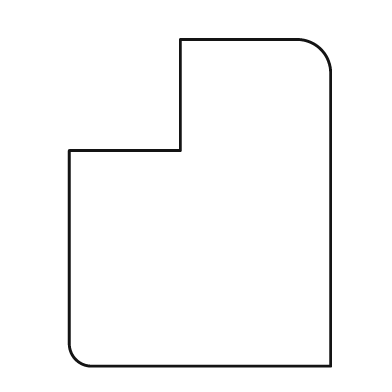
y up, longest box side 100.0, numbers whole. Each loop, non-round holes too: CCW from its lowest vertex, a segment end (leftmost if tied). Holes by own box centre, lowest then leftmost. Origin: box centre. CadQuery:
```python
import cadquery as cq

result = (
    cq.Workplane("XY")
    .moveTo(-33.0, -50.0)
    .lineTo(40.0, -50.0)
    .lineTo(40.0, 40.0)
    .threePointArc((37.0, 47.0), (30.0, 50.0))
    .lineTo(-6.0, 50.0)
    .lineTo(-6.0, 16.0)
    .lineTo(-40.0, 16.0)
    .lineTo(-40.0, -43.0)
    .threePointArc((-38.0, -48.0), (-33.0, -50.0))
    .close()
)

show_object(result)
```